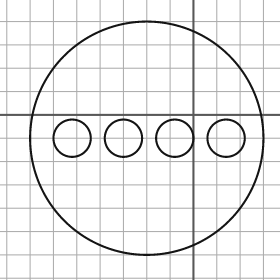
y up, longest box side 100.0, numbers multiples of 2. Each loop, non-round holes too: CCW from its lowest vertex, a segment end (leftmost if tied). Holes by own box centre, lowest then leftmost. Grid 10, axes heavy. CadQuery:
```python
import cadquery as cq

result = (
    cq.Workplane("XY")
    .moveTo(-20.0, -10.0)
    .circle(50.0)
    .moveTo(-52.0, -10.0)
    .circle(8.0)
    .moveTo(-30.0, -10.0)
    .circle(8.0)
    .moveTo(-8.0, -10.0)
    .circle(8.0)
    .moveTo(14.0, -10.0)
    .circle(8.0)
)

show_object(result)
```